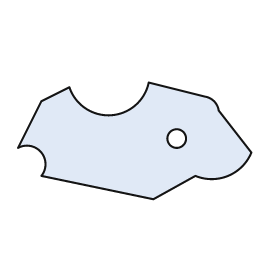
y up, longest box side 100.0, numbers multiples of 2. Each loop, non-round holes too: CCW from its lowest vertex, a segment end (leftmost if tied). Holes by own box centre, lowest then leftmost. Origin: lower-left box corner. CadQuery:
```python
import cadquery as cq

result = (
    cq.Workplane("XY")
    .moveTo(58.0, 0.0)
    .lineTo(76.0, 10.0)
    .threePointArc((90.0, 10.0), (100.0, 20.0))
    .lineTo(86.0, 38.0)
    .threePointArc((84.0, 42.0), (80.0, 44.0))
    .lineTo(56.0, 50.0)
    .threePointArc((40.0, 36.0), (22.0, 48.0))
    .lineTo(10.0, 42.0)
    .lineTo(0.0, 22.0)
    .threePointArc((10.0, 20.0), (10.0, 10.0))
    .close()
    .moveTo(68.0, 26.0)
    .circle(4.0)
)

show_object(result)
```